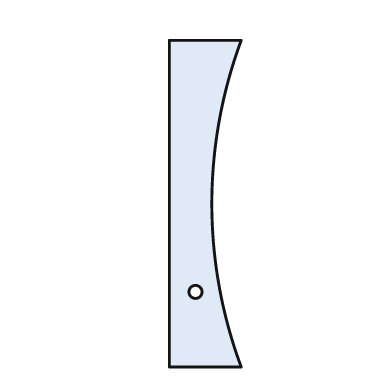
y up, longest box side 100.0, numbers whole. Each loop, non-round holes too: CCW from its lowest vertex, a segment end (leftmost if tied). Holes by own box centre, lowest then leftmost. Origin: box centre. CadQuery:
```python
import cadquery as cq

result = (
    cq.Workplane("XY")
    .moveTo(-11.0, -50.0)
    .lineTo(11.0, -50.0)
    .threePointArc((2.0, 0.0), (11.0, 50.0))
    .lineTo(-11.0, 50.0)
    .close()
    .moveTo(-3.0, -27.0)
    .circle(2.0)
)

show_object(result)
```